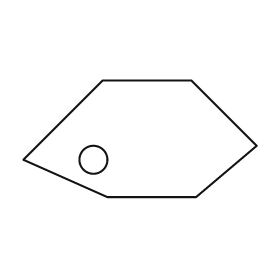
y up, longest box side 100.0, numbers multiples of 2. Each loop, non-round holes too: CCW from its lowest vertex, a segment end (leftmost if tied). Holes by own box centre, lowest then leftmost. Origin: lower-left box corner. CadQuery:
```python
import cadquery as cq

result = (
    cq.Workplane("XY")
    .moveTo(36.0, 0.0)
    .lineTo(74.0, 0.0)
    .lineTo(100.0, 22.0)
    .lineTo(72.0, 50.0)
    .lineTo(34.0, 50.0)
    .lineTo(0.0, 16.0)
    .close()
    .moveTo(30.0, 16.0)
    .circle(6.0)
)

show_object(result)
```